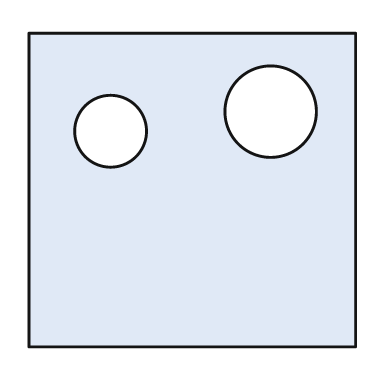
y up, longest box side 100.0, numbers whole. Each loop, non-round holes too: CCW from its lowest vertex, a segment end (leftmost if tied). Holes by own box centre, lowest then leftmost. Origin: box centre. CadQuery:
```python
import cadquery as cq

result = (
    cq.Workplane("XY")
    .moveTo(-50.0, -48.0)
    .lineTo(50.0, -48.0)
    .lineTo(50.0, 48.0)
    .lineTo(-50.0, 48.0)
    .close()
    .moveTo(-25.0, 18.0)
    .circle(11.0)
    .moveTo(24.0, 24.0)
    .circle(14.0)
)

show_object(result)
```